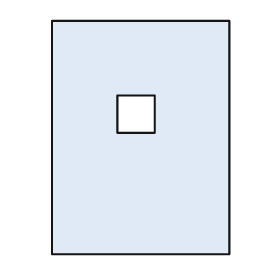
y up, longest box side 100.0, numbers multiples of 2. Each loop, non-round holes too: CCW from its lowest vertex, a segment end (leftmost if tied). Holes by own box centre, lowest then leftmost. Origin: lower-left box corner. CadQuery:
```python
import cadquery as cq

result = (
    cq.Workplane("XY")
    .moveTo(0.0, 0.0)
    .lineTo(76.0, 0.0)
    .lineTo(76.0, 100.0)
    .lineTo(0.0, 100.0)
    .close()
    .moveTo(28.0, 52.0)
    .lineTo(44.0, 52.0)
    .lineTo(44.0, 68.0)
    .lineTo(28.0, 68.0)
    .close()
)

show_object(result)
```